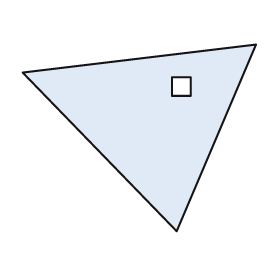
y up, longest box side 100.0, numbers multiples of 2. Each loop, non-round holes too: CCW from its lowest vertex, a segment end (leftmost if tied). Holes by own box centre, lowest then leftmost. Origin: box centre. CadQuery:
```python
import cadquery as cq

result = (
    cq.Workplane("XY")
    .moveTo(16.0, -40.0)
    .lineTo(50.0, 40.0)
    .lineTo(-50.0, 28.0)
    .close()
    .moveTo(14.0, 18.0)
    .lineTo(22.0, 18.0)
    .lineTo(22.0, 26.0)
    .lineTo(14.0, 26.0)
    .close()
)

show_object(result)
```